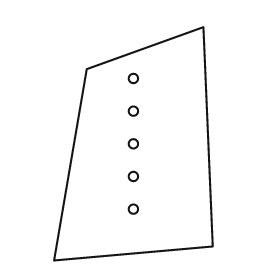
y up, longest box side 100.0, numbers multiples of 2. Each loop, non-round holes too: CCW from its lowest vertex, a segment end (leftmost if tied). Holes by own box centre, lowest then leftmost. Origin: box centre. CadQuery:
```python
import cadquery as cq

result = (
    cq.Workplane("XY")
    .moveTo(-34.0, -50.0)
    .lineTo(34.0, -44.0)
    .lineTo(30.0, 50.0)
    .lineTo(-20.0, 32.0)
    .close()
    .moveTo(0.0, -28.0)
    .circle(2.0)
    .moveTo(0.0, -14.0)
    .circle(2.0)
    .moveTo(0.0, 0.0)
    .circle(2.0)
    .moveTo(0.0, 14.0)
    .circle(2.0)
    .moveTo(0.0, 28.0)
    .circle(2.0)
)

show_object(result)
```